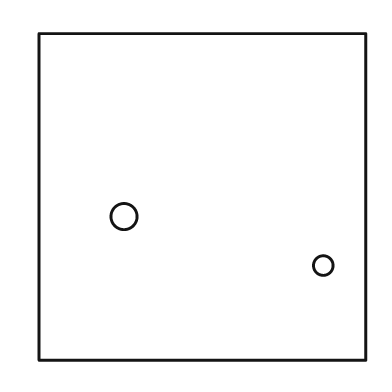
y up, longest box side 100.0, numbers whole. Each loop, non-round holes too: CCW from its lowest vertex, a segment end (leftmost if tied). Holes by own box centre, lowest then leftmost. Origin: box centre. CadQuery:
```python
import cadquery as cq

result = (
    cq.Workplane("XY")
    .moveTo(-50.0, -50.0)
    .lineTo(50.0, -50.0)
    .lineTo(50.0, 50.0)
    .lineTo(-50.0, 50.0)
    .close()
    .moveTo(37.0, -21.0)
    .circle(3.0)
    .moveTo(-24.0, -6.0)
    .circle(4.0)
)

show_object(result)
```